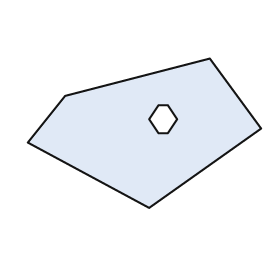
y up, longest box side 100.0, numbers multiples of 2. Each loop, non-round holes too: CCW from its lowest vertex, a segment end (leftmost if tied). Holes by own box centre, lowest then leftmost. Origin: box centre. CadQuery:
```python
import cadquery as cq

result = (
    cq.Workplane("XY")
    .moveTo(2.0, -32.0)
    .lineTo(50.0, 2.0)
    .lineTo(28.0, 32.0)
    .lineTo(-34.0, 16.0)
    .lineTo(-50.0, -4.0)
    .close()
    .moveTo(6.0, 0.0)
    .lineTo(10.0, 0.0)
    .lineTo(14.0, 6.0)
    .lineTo(10.0, 12.0)
    .lineTo(6.0, 12.0)
    .lineTo(2.0, 6.0)
    .close()
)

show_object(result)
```